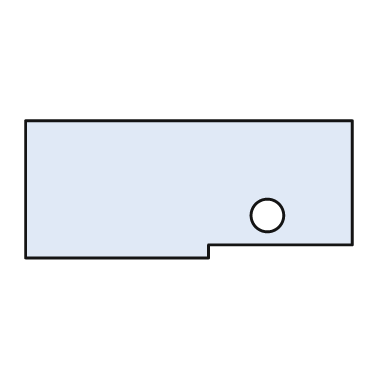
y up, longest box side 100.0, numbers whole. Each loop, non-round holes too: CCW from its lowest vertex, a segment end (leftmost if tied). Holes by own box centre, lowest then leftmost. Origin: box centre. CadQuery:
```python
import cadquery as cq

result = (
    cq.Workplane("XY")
    .moveTo(-50.0, -21.0)
    .lineTo(6.0, -21.0)
    .lineTo(6.0, -17.0)
    .lineTo(50.0, -17.0)
    .lineTo(50.0, 21.0)
    .lineTo(-50.0, 21.0)
    .close()
    .moveTo(24.0, -8.0)
    .circle(5.0)
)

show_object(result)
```